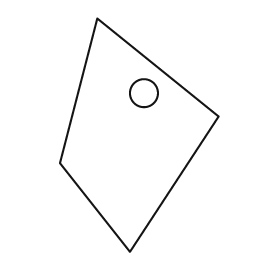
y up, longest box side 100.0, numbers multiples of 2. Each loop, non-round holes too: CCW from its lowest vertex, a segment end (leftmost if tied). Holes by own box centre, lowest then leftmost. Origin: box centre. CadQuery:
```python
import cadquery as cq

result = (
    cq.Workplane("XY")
    .moveTo(-4.0, -50.0)
    .lineTo(34.0, 8.0)
    .lineTo(-18.0, 50.0)
    .lineTo(-34.0, -12.0)
    .close()
    .moveTo(2.0, 18.0)
    .circle(6.0)
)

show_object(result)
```